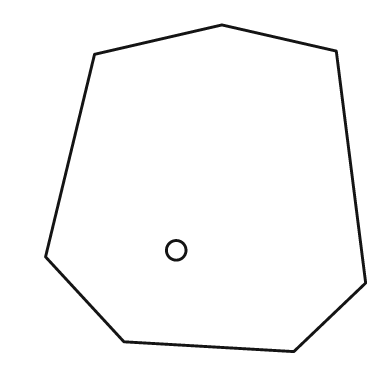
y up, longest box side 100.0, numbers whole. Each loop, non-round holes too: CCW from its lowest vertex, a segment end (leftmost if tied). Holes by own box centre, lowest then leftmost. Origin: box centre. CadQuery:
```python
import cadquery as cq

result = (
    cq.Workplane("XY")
    .moveTo(27.0, -50.0)
    .lineTo(49.0, -29.0)
    .lineTo(40.0, 42.0)
    .lineTo(5.0, 50.0)
    .lineTo(-34.0, 41.0)
    .lineTo(-49.0, -21.0)
    .lineTo(-25.0, -47.0)
    .close()
    .moveTo(-9.0, -19.0)
    .circle(3.0)
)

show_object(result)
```